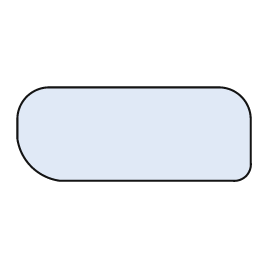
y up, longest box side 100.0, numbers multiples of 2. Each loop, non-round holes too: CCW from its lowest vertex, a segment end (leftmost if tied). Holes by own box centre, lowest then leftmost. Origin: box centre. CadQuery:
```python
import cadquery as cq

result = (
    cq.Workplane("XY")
    .moveTo(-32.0, -20.0)
    .lineTo(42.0, -20.0)
    .threePointArc((48.0, -18.0), (50.0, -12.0))
    .lineTo(50.0, 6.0)
    .threePointArc((46.0, 16.0), (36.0, 20.0))
    .lineTo(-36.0, 20.0)
    .threePointArc((-46.0, 16.0), (-50.0, 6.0))
    .lineTo(-50.0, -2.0)
    .threePointArc((-44.0, -14.0), (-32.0, -20.0))
    .close()
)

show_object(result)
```